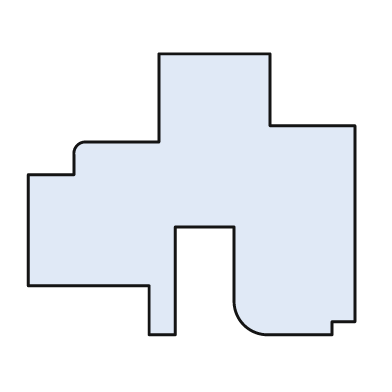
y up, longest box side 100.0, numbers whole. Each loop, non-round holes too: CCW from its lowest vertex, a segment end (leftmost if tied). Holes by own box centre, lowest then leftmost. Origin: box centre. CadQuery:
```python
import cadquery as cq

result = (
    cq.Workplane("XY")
    .moveTo(-13.0, -43.0)
    .lineTo(-5.0, -43.0)
    .lineTo(-5.0, -10.0)
    .lineTo(13.0, -10.0)
    .lineTo(13.0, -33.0)
    .threePointArc((16.0, -40.0), (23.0, -43.0))
    .lineTo(43.0, -43.0)
    .lineTo(43.0, -39.0)
    .lineTo(50.0, -39.0)
    .lineTo(50.0, 21.0)
    .lineTo(24.0, 21.0)
    .lineTo(24.0, 43.0)
    .lineTo(-10.0, 43.0)
    .lineTo(-10.0, 16.0)
    .lineTo(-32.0, 16.0)
    .threePointArc((-35.0, 15.0), (-36.0, 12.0))
    .lineTo(-36.0, 6.0)
    .lineTo(-50.0, 6.0)
    .lineTo(-50.0, -28.0)
    .lineTo(-13.0, -28.0)
    .close()
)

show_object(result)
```